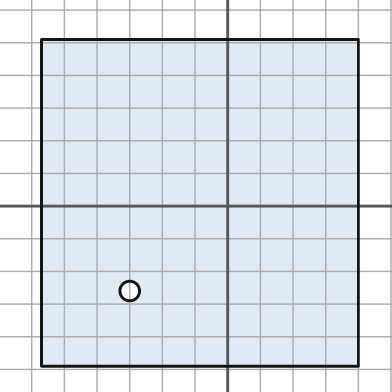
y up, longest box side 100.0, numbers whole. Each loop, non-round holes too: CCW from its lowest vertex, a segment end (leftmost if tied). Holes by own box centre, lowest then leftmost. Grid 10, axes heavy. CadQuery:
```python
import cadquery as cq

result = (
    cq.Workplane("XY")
    .moveTo(-57.0, -49.0)
    .lineTo(40.0, -49.0)
    .lineTo(40.0, 51.0)
    .lineTo(-57.0, 51.0)
    .close()
    .moveTo(-30.0, -26.0)
    .circle(3.0)
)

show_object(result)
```